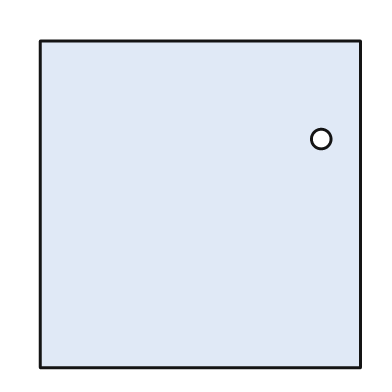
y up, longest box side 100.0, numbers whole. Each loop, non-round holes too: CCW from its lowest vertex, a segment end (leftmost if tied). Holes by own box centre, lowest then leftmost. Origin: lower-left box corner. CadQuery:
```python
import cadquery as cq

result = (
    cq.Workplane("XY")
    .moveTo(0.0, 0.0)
    .lineTo(98.0, 0.0)
    .lineTo(98.0, 100.0)
    .lineTo(0.0, 100.0)
    .close()
    .moveTo(86.0, 70.0)
    .circle(3.0)
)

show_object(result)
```